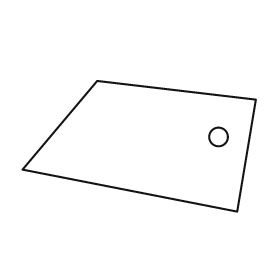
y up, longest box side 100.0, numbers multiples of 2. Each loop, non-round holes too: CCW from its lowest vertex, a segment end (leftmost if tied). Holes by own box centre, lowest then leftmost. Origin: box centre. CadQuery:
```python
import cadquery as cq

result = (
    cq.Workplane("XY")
    .moveTo(42.0, -28.0)
    .lineTo(50.0, 20.0)
    .lineTo(-18.0, 28.0)
    .lineTo(-50.0, -10.0)
    .close()
    .moveTo(34.0, 4.0)
    .circle(4.0)
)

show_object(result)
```